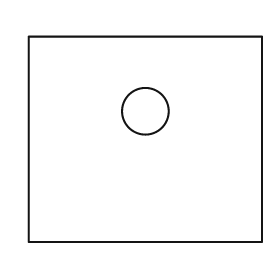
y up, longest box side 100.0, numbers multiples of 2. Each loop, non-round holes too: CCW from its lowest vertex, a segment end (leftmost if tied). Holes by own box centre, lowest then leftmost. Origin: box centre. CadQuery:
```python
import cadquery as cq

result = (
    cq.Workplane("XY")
    .moveTo(-50.0, -44.0)
    .lineTo(50.0, -44.0)
    .lineTo(50.0, 44.0)
    .lineTo(-50.0, 44.0)
    .close()
    .moveTo(0.0, 12.0)
    .circle(10.0)
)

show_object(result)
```